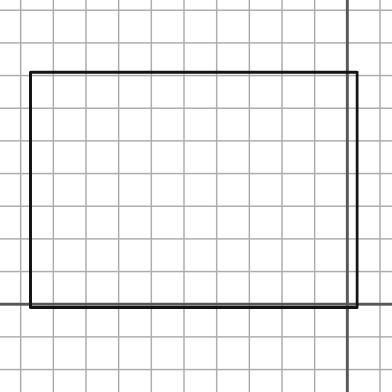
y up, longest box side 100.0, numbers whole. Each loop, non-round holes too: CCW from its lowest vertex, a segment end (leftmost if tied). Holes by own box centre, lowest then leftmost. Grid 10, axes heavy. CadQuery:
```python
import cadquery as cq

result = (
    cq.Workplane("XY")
    .moveTo(-97.0, -1.0)
    .lineTo(3.0, -1.0)
    .lineTo(3.0, 71.0)
    .lineTo(-97.0, 71.0)
    .close()
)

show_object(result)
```